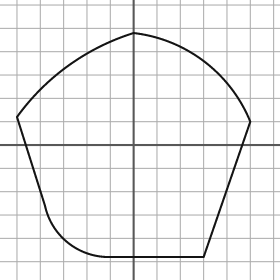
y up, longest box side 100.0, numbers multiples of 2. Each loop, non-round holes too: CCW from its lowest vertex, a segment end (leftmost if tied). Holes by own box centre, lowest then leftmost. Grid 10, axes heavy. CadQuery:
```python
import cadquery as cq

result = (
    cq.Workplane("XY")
    .moveTo(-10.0, -48.0)
    .lineTo(30.0, -48.0)
    .lineTo(50.0, 10.0)
    .threePointArc((30.0, 36.0), (0.0, 48.0))
    .threePointArc((-28.0, 34.0), (-50.0, 12.0))
    .lineTo(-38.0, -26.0)
    .threePointArc((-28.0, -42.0), (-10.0, -48.0))
    .close()
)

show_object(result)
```